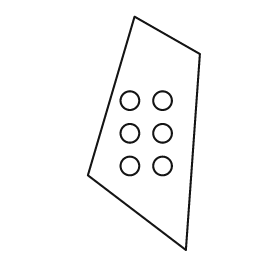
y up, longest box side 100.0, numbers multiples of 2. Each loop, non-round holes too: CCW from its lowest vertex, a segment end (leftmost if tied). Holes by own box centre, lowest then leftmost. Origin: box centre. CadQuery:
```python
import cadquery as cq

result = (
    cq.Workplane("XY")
    .moveTo(18.0, -50.0)
    .lineTo(24.0, 34.0)
    .lineTo(-4.0, 50.0)
    .lineTo(-24.0, -18.0)
    .close()
    .moveTo(-6.0, -14.0)
    .circle(4.0)
    .moveTo(8.0, -14.0)
    .circle(4.0)
    .moveTo(-6.0, 0.0)
    .circle(4.0)
    .moveTo(8.0, 0.0)
    .circle(4.0)
    .moveTo(-6.0, 14.0)
    .circle(4.0)
    .moveTo(8.0, 14.0)
    .circle(4.0)
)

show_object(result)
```